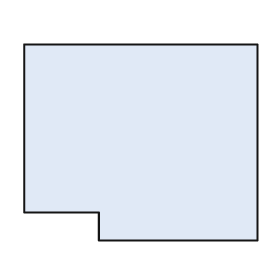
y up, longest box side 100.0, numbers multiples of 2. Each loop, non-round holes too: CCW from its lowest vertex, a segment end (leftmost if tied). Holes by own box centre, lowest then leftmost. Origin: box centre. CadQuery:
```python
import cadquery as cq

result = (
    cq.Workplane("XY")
    .moveTo(-18.0, -42.0)
    .lineTo(50.0, -42.0)
    .lineTo(50.0, 42.0)
    .lineTo(-50.0, 42.0)
    .lineTo(-50.0, -30.0)
    .lineTo(-18.0, -30.0)
    .close()
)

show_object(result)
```